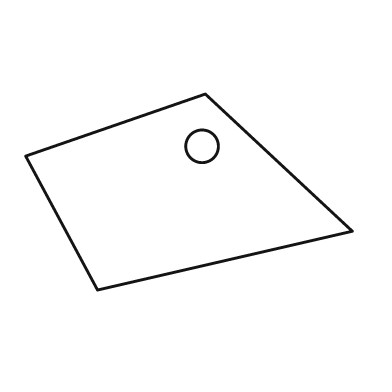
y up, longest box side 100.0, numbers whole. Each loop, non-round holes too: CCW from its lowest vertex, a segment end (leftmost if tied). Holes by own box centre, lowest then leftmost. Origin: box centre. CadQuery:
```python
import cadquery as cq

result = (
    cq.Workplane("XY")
    .moveTo(-28.0, -30.0)
    .lineTo(50.0, -12.0)
    .lineTo(5.0, 30.0)
    .lineTo(-50.0, 11.0)
    .close()
    .moveTo(4.0, 14.0)
    .circle(5.0)
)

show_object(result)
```